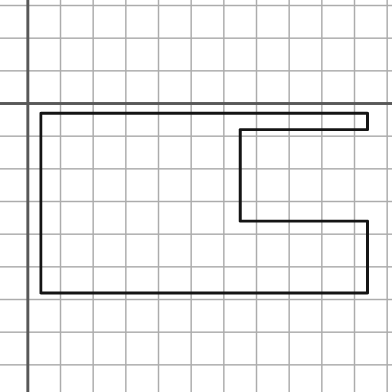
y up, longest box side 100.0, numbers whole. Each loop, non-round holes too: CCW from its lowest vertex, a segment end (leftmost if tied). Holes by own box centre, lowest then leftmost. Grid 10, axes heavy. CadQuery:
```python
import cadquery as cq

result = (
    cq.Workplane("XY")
    .moveTo(4.0, -58.0)
    .lineTo(104.0, -58.0)
    .lineTo(104.0, -36.0)
    .lineTo(65.0, -36.0)
    .lineTo(65.0, -8.0)
    .lineTo(104.0, -8.0)
    .lineTo(104.0, -3.0)
    .lineTo(4.0, -3.0)
    .close()
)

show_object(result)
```